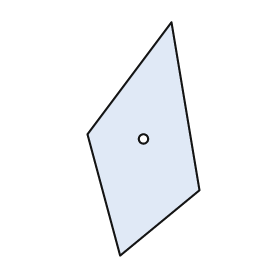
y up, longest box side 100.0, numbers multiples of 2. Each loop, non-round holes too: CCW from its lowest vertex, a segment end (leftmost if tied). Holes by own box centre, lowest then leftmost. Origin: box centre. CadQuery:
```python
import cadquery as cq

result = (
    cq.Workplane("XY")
    .moveTo(-10.0, -50.0)
    .lineTo(24.0, -22.0)
    .lineTo(12.0, 50.0)
    .lineTo(-24.0, 2.0)
    .close()
    .moveTo(0.0, 0.0)
    .circle(2.0)
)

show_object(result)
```